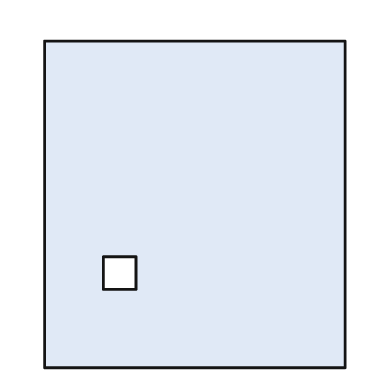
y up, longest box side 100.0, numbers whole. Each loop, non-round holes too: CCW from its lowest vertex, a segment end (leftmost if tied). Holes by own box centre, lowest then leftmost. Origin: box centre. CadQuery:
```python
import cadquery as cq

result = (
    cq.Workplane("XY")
    .moveTo(-46.0, -50.0)
    .lineTo(46.0, -50.0)
    .lineTo(46.0, 50.0)
    .lineTo(-46.0, 50.0)
    .close()
    .moveTo(-28.0, -26.0)
    .lineTo(-18.0, -26.0)
    .lineTo(-18.0, -16.0)
    .lineTo(-28.0, -16.0)
    .close()
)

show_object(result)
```